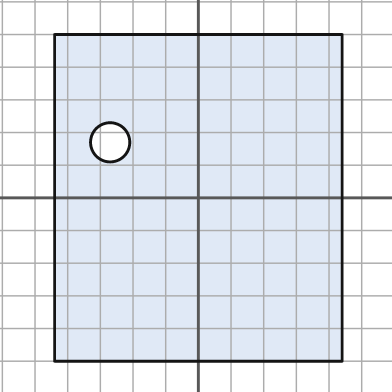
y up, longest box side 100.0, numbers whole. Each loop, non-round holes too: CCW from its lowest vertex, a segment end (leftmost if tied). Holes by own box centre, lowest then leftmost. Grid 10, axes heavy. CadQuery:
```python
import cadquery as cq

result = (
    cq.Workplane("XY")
    .moveTo(-44.0, -50.0)
    .lineTo(44.0, -50.0)
    .lineTo(44.0, 50.0)
    .lineTo(-44.0, 50.0)
    .close()
    .moveTo(-27.0, 17.0)
    .circle(6.0)
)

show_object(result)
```